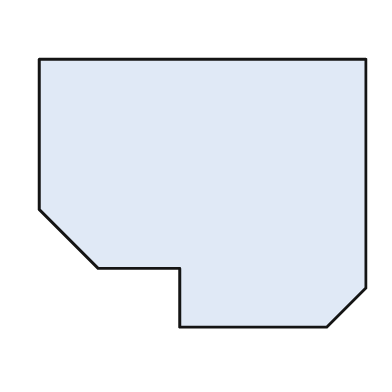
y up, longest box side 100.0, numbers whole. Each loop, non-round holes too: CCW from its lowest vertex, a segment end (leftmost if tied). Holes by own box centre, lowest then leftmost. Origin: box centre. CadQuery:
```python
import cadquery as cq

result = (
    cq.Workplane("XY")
    .moveTo(-7.0, -41.0)
    .lineTo(38.0, -41.0)
    .lineTo(50.0, -29.0)
    .lineTo(50.0, 41.0)
    .lineTo(-50.0, 41.0)
    .lineTo(-50.0, -5.0)
    .lineTo(-32.0, -23.0)
    .lineTo(-7.0, -23.0)
    .close()
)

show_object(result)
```